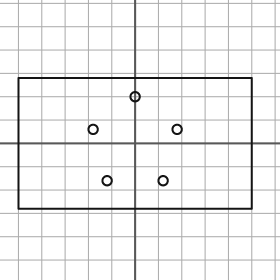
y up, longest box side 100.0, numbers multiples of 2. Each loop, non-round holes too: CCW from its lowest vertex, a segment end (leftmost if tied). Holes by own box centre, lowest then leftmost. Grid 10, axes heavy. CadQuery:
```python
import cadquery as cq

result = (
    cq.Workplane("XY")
    .moveTo(-50.0, -28.0)
    .lineTo(50.0, -28.0)
    .lineTo(50.0, 28.0)
    .lineTo(-50.0, 28.0)
    .close()
    .moveTo(-12.0, -16.0)
    .circle(2.0)
    .moveTo(12.0, -16.0)
    .circle(2.0)
    .moveTo(-18.0, 6.0)
    .circle(2.0)
    .moveTo(18.0, 6.0)
    .circle(2.0)
    .moveTo(0.0, 20.0)
    .circle(2.0)
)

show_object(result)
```